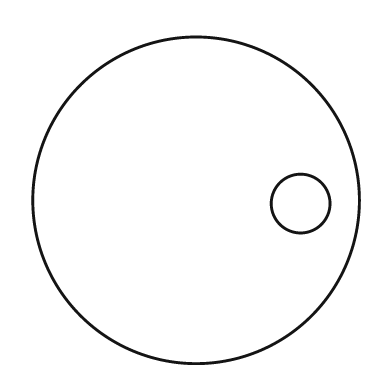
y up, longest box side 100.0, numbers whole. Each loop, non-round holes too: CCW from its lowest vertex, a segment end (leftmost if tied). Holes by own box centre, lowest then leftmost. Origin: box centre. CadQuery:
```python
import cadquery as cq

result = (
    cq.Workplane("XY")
    .moveTo(0.0, 0.0)
    .circle(50.0)
    .moveTo(32.0, -1.0)
    .circle(9.0)
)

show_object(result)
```